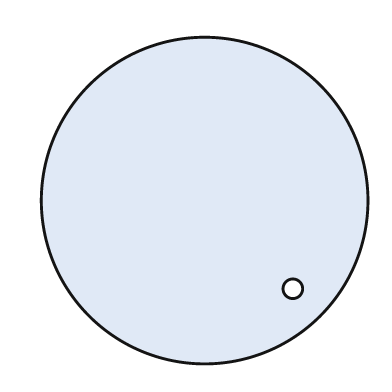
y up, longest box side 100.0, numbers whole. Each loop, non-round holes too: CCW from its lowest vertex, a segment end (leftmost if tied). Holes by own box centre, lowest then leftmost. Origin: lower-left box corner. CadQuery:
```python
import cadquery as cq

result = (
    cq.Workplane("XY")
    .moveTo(50.0, 50.0)
    .circle(50.0)
    .moveTo(77.0, 23.0)
    .circle(3.0)
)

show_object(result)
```